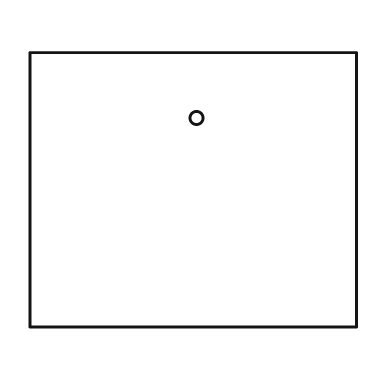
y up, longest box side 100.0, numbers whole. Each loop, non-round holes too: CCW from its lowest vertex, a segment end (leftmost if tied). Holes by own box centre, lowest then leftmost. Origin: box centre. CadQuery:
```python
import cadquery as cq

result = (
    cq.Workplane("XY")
    .moveTo(-50.0, -42.0)
    .lineTo(50.0, -42.0)
    .lineTo(50.0, 42.0)
    .lineTo(-50.0, 42.0)
    .close()
    .moveTo(1.0, 22.0)
    .circle(2.0)
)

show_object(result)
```